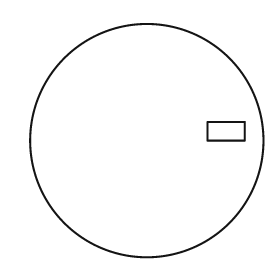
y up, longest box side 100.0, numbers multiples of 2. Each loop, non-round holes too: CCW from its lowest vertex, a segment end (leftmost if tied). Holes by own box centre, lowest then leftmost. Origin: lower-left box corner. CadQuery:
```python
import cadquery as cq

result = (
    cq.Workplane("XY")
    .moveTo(50.0, 50.0)
    .circle(50.0)
    .moveTo(76.0, 50.0)
    .lineTo(92.0, 50.0)
    .lineTo(92.0, 58.0)
    .lineTo(76.0, 58.0)
    .close()
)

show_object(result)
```